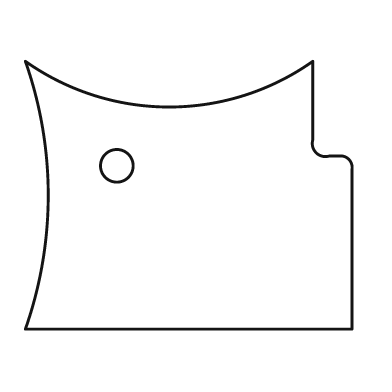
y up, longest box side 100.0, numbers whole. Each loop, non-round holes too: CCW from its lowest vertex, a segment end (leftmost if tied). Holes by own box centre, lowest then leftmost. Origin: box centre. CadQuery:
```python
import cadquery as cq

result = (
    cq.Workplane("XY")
    .moveTo(-50.0, -41.0)
    .lineTo(50.0, -41.0)
    .lineTo(50.0, 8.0)
    .threePointArc((49.0, 11.0), (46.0, 12.0))
    .lineTo(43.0, 12.0)
    .threePointArc((39.0, 13.0), (38.0, 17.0))
    .lineTo(38.0, 41.0)
    .threePointArc((-6.0, 27.0), (-50.0, 41.0))
    .threePointArc((-43.0, 0.0), (-50.0, -41.0))
    .close()
    .moveTo(-22.0, 9.0)
    .circle(5.0)
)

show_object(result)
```